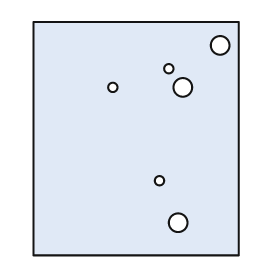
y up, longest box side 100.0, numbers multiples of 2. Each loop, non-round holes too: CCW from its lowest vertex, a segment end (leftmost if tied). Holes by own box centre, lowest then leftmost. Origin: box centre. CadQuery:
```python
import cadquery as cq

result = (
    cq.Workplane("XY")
    .moveTo(-44.0, -50.0)
    .lineTo(44.0, -50.0)
    .lineTo(44.0, 50.0)
    .lineTo(-44.0, 50.0)
    .close()
    .moveTo(18.0, -36.0)
    .circle(4.0)
    .moveTo(10.0, -18.0)
    .circle(2.0)
    .moveTo(-10.0, 22.0)
    .circle(2.0)
    .moveTo(20.0, 22.0)
    .circle(4.0)
    .moveTo(14.0, 30.0)
    .circle(2.0)
    .moveTo(36.0, 40.0)
    .circle(4.0)
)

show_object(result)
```